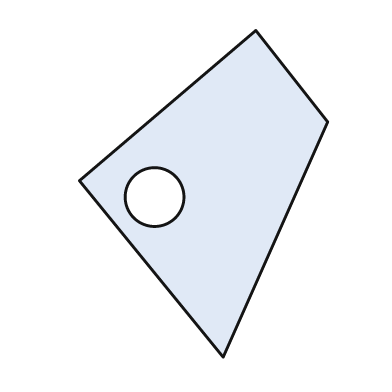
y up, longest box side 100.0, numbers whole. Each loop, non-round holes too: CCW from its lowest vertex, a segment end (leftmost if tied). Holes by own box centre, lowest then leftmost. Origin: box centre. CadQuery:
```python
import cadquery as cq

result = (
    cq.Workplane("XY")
    .moveTo(6.0, -50.0)
    .lineTo(38.0, 22.0)
    .lineTo(16.0, 50.0)
    .lineTo(-38.0, 4.0)
    .close()
    .moveTo(-15.0, -1.0)
    .circle(9.0)
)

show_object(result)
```